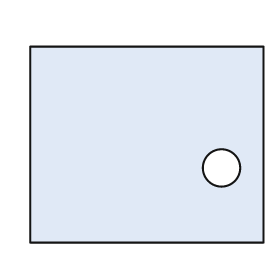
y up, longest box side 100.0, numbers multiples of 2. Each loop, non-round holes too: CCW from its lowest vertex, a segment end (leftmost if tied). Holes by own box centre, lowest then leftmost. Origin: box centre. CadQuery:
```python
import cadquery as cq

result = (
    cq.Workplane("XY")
    .moveTo(-50.0, -42.0)
    .lineTo(50.0, -42.0)
    .lineTo(50.0, 42.0)
    .lineTo(-50.0, 42.0)
    .close()
    .moveTo(32.0, -10.0)
    .circle(8.0)
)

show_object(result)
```